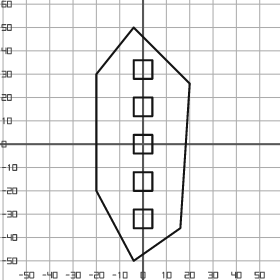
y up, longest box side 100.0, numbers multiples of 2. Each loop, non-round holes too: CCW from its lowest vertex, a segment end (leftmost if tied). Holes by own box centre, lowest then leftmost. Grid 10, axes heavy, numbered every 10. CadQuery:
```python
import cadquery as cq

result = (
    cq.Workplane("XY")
    .moveTo(-4.0, -50.0)
    .lineTo(16.0, -36.0)
    .lineTo(20.0, 26.0)
    .lineTo(-4.0, 50.0)
    .lineTo(-20.0, 30.0)
    .lineTo(-20.0, -20.0)
    .close()
    .moveTo(-4.0, -36.0)
    .lineTo(4.0, -36.0)
    .lineTo(4.0, -28.0)
    .lineTo(-4.0, -28.0)
    .close()
    .moveTo(-4.0, -20.0)
    .lineTo(4.0, -20.0)
    .lineTo(4.0, -12.0)
    .lineTo(-4.0, -12.0)
    .close()
    .moveTo(-4.0, -4.0)
    .lineTo(4.0, -4.0)
    .lineTo(4.0, 4.0)
    .lineTo(-4.0, 4.0)
    .close()
    .moveTo(-4.0, 12.0)
    .lineTo(4.0, 12.0)
    .lineTo(4.0, 20.0)
    .lineTo(-4.0, 20.0)
    .close()
    .moveTo(-4.0, 28.0)
    .lineTo(4.0, 28.0)
    .lineTo(4.0, 36.0)
    .lineTo(-4.0, 36.0)
    .close()
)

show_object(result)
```